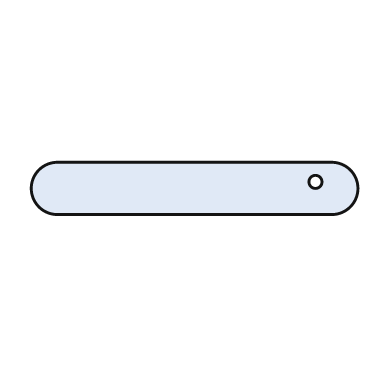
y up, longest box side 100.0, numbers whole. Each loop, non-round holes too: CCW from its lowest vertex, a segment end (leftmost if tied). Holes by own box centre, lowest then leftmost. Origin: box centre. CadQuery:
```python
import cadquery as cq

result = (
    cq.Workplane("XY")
    .moveTo(-42.0, -8.0)
    .lineTo(42.0, -8.0)
    .threePointArc((50.0, 0.0), (42.0, 8.0))
    .lineTo(-42.0, 8.0)
    .threePointArc((-50.0, 0.0), (-42.0, -8.0))
    .close()
    .moveTo(37.0, 2.0)
    .circle(2.0)
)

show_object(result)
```